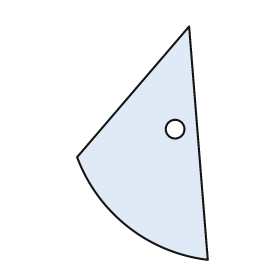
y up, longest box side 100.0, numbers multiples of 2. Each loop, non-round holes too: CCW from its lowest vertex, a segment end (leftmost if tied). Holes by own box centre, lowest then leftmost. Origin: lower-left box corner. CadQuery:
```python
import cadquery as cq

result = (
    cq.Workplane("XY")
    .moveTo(56.0, 0.0)
    .lineTo(48.0, 100.0)
    .lineTo(0.0, 44.0)
    .threePointArc((22.0, 14.0), (56.0, 0.0))
    .close()
    .moveTo(42.0, 56.0)
    .circle(4.0)
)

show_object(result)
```